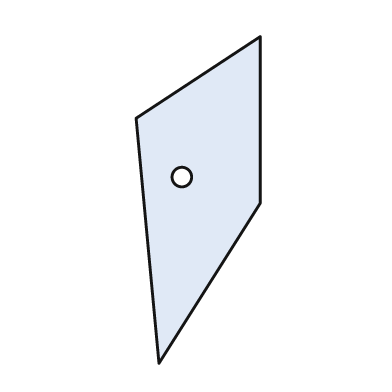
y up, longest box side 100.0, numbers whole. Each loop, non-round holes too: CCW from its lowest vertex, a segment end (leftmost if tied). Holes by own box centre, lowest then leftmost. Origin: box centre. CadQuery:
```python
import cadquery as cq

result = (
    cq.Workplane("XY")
    .moveTo(-12.0, -50.0)
    .lineTo(19.0, -1.0)
    .lineTo(19.0, 50.0)
    .lineTo(-19.0, 25.0)
    .close()
    .moveTo(-5.0, 7.0)
    .circle(3.0)
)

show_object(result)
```